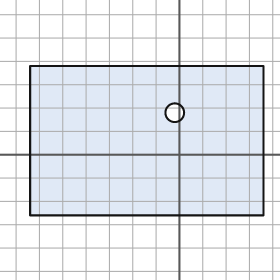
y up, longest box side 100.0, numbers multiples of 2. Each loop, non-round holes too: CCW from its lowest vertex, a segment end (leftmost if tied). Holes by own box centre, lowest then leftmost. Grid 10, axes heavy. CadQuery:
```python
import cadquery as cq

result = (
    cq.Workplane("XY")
    .moveTo(-64.0, -26.0)
    .lineTo(36.0, -26.0)
    .lineTo(36.0, 38.0)
    .lineTo(-64.0, 38.0)
    .close()
    .moveTo(-2.0, 18.0)
    .circle(4.0)
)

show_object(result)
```